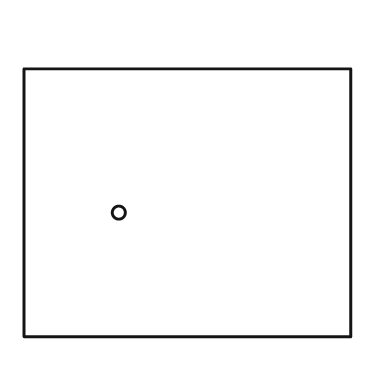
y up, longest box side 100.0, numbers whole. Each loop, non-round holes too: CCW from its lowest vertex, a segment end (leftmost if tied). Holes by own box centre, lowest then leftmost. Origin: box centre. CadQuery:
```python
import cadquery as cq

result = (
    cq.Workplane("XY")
    .moveTo(-50.0, -41.0)
    .lineTo(50.0, -41.0)
    .lineTo(50.0, 41.0)
    .lineTo(-50.0, 41.0)
    .close()
    .moveTo(-21.0, -3.0)
    .circle(2.0)
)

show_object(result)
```